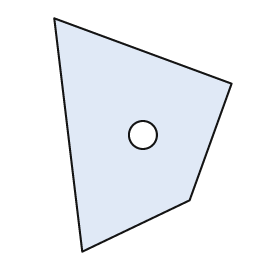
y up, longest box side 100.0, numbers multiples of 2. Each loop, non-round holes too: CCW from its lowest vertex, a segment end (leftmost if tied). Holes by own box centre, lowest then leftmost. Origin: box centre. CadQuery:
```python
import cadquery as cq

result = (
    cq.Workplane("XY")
    .moveTo(-26.0, -50.0)
    .lineTo(20.0, -28.0)
    .lineTo(38.0, 22.0)
    .lineTo(-38.0, 50.0)
    .close()
    .moveTo(0.0, 0.0)
    .circle(6.0)
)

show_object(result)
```